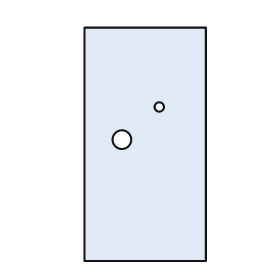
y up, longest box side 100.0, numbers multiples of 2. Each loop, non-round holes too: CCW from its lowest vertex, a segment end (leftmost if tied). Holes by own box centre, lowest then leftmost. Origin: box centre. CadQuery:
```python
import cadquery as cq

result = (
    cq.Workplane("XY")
    .moveTo(-26.0, -50.0)
    .lineTo(26.0, -50.0)
    .lineTo(26.0, 50.0)
    .lineTo(-26.0, 50.0)
    .close()
    .moveTo(-10.0, 2.0)
    .circle(4.0)
    .moveTo(6.0, 16.0)
    .circle(2.0)
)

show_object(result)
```